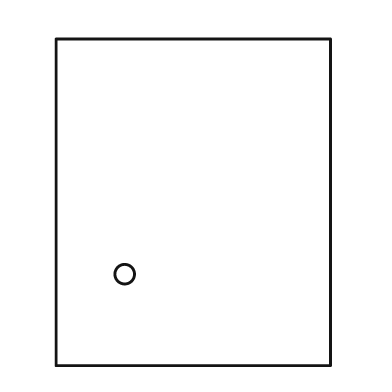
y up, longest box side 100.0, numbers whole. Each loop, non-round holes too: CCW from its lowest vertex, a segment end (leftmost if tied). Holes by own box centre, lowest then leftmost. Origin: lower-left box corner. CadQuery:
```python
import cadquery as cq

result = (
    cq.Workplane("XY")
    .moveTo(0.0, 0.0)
    .lineTo(84.0, 0.0)
    .lineTo(84.0, 100.0)
    .lineTo(0.0, 100.0)
    .close()
    .moveTo(21.0, 28.0)
    .circle(3.0)
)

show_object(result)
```